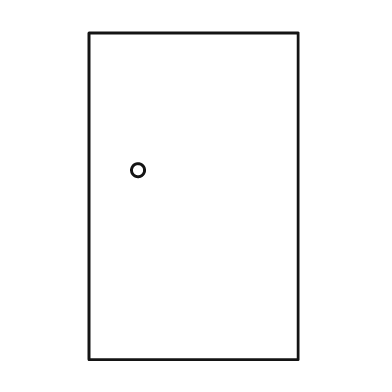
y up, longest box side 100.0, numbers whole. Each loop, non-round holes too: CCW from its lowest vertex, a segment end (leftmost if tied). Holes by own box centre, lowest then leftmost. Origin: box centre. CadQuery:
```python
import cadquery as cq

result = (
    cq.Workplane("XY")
    .moveTo(-32.0, -50.0)
    .lineTo(32.0, -50.0)
    .lineTo(32.0, 50.0)
    .lineTo(-32.0, 50.0)
    .close()
    .moveTo(-17.0, 8.0)
    .circle(2.0)
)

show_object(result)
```